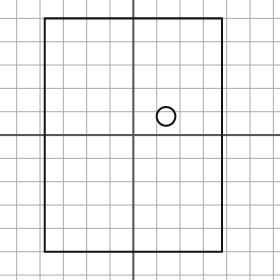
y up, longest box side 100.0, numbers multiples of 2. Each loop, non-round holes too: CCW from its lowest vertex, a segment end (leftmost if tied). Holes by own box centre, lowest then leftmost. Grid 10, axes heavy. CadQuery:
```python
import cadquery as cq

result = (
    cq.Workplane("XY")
    .moveTo(-38.0, -50.0)
    .lineTo(38.0, -50.0)
    .lineTo(38.0, 50.0)
    .lineTo(-38.0, 50.0)
    .close()
    .moveTo(14.0, 8.0)
    .circle(4.0)
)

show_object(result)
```